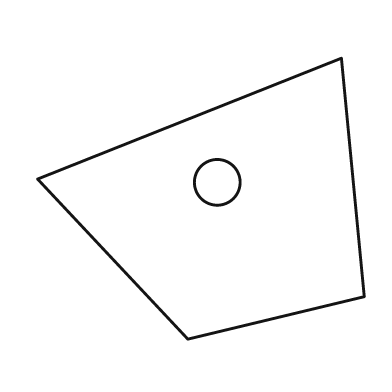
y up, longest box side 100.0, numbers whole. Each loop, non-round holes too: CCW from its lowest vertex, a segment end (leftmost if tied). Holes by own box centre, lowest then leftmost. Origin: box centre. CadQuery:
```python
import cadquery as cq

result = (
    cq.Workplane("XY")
    .moveTo(-4.0, -43.0)
    .lineTo(50.0, -30.0)
    .lineTo(43.0, 43.0)
    .lineTo(-50.0, 6.0)
    .close()
    .moveTo(5.0, 5.0)
    .circle(7.0)
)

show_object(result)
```